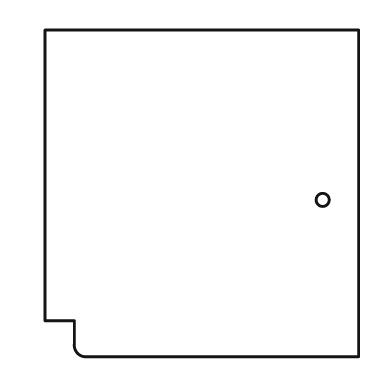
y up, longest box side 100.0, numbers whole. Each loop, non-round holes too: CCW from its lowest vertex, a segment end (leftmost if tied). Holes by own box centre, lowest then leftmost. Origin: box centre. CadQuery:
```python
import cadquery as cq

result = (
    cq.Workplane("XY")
    .moveTo(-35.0, -50.0)
    .lineTo(48.0, -50.0)
    .lineTo(48.0, 50.0)
    .lineTo(-48.0, 50.0)
    .lineTo(-48.0, -39.0)
    .lineTo(-39.0, -39.0)
    .lineTo(-39.0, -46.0)
    .threePointArc((-38.0, -49.0), (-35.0, -50.0))
    .close()
    .moveTo(37.0, -2.0)
    .circle(2.0)
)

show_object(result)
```